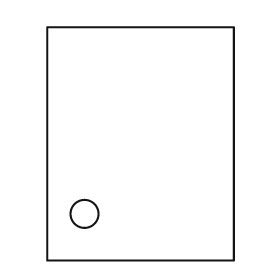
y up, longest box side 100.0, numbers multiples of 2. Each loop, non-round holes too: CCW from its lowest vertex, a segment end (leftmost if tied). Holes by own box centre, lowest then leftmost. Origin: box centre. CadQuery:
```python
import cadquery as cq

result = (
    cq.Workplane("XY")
    .moveTo(-40.0, -50.0)
    .lineTo(40.0, -50.0)
    .lineTo(40.0, 50.0)
    .lineTo(-40.0, 50.0)
    .close()
    .moveTo(-24.0, -30.0)
    .circle(6.0)
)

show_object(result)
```